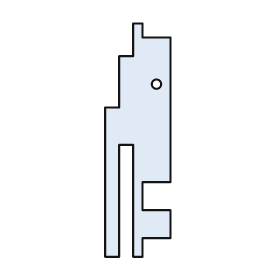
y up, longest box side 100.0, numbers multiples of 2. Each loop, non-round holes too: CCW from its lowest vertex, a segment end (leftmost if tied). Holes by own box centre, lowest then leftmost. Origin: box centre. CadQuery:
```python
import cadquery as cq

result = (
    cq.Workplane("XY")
    .moveTo(-14.0, -50.0)
    .lineTo(-8.0, -50.0)
    .lineTo(-8.0, -2.0)
    .lineTo(-2.0, -2.0)
    .lineTo(-2.0, -50.0)
    .lineTo(2.0, -50.0)
    .lineTo(2.0, -42.0)
    .lineTo(14.0, -42.0)
    .lineTo(14.0, -30.0)
    .lineTo(2.0, -30.0)
    .lineTo(2.0, -18.0)
    .lineTo(14.0, -18.0)
    .lineTo(14.0, 44.0)
    .lineTo(2.0, 44.0)
    .lineTo(2.0, 50.0)
    .lineTo(-2.0, 50.0)
    .lineTo(-2.0, 36.0)
    .lineTo(-8.0, 36.0)
    .lineTo(-8.0, 14.0)
    .lineTo(-14.0, 14.0)
    .close()
    .moveTo(8.0, 24.0)
    .circle(2.0)
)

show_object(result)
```